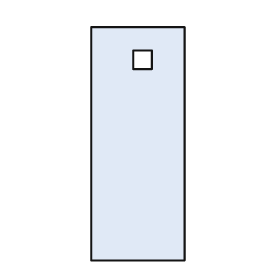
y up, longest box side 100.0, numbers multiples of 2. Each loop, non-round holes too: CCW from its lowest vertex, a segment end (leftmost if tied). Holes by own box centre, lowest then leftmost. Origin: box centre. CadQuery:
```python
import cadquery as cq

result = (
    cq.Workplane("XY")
    .moveTo(-20.0, -50.0)
    .lineTo(20.0, -50.0)
    .lineTo(20.0, 50.0)
    .lineTo(-20.0, 50.0)
    .close()
    .moveTo(-2.0, 32.0)
    .lineTo(6.0, 32.0)
    .lineTo(6.0, 40.0)
    .lineTo(-2.0, 40.0)
    .close()
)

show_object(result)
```